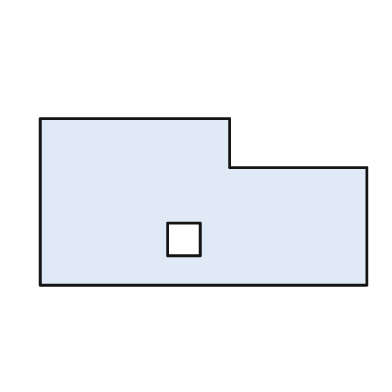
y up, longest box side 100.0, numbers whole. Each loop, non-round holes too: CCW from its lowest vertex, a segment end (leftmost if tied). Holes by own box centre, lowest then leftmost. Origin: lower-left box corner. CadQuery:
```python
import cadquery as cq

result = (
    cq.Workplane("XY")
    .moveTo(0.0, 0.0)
    .lineTo(100.0, 0.0)
    .lineTo(100.0, 36.0)
    .lineTo(58.0, 36.0)
    .lineTo(58.0, 51.0)
    .lineTo(0.0, 51.0)
    .close()
    .moveTo(39.0, 9.0)
    .lineTo(49.0, 9.0)
    .lineTo(49.0, 19.0)
    .lineTo(39.0, 19.0)
    .close()
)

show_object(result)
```